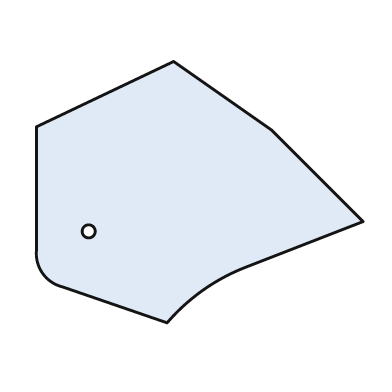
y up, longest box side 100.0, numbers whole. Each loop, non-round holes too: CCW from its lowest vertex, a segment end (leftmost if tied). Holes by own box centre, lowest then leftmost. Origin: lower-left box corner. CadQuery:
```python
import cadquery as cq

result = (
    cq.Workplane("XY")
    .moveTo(40.0, 0.0)
    .threePointArc((51.0, 10.0), (64.0, 17.0))
    .lineTo(100.0, 31.0)
    .lineTo(72.0, 59.0)
    .lineTo(42.0, 80.0)
    .lineTo(0.0, 60.0)
    .lineTo(0.0, 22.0)
    .threePointArc((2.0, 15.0), (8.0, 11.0))
    .close()
    .moveTo(16.0, 28.0)
    .circle(2.0)
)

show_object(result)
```